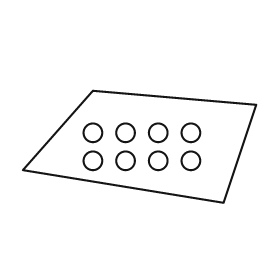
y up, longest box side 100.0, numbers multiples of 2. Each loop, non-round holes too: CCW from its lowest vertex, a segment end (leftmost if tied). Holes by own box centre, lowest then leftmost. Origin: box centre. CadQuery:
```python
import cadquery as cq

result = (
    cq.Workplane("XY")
    .moveTo(36.0, -24.0)
    .lineTo(50.0, 18.0)
    .lineTo(-20.0, 24.0)
    .lineTo(-50.0, -10.0)
    .close()
    .moveTo(-20.0, -6.0)
    .circle(4.0)
    .moveTo(-6.0, -6.0)
    .circle(4.0)
    .moveTo(8.0, -6.0)
    .circle(4.0)
    .moveTo(22.0, -6.0)
    .circle(4.0)
    .moveTo(-20.0, 6.0)
    .circle(4.0)
    .moveTo(-6.0, 6.0)
    .circle(4.0)
    .moveTo(8.0, 6.0)
    .circle(4.0)
    .moveTo(22.0, 6.0)
    .circle(4.0)
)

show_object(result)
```